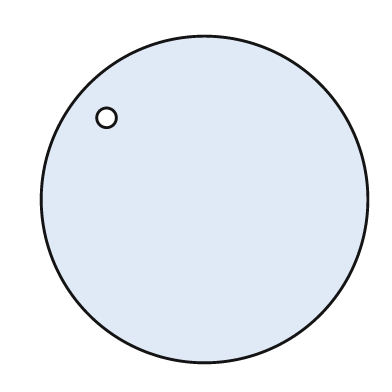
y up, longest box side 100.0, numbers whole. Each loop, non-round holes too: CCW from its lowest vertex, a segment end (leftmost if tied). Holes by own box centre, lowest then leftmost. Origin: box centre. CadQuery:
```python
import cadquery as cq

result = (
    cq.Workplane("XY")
    .moveTo(0.0, 0.0)
    .circle(50.0)
    .moveTo(-30.0, 25.0)
    .circle(3.0)
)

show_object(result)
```